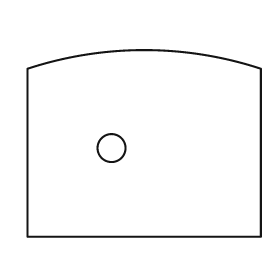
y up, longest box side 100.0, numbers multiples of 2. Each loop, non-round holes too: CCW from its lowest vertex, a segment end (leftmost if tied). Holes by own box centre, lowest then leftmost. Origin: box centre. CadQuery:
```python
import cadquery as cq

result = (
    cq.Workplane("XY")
    .moveTo(-50.0, -40.0)
    .lineTo(50.0, -40.0)
    .lineTo(50.0, 32.0)
    .threePointArc((0.0, 40.0), (-50.0, 32.0))
    .close()
    .moveTo(-14.0, -2.0)
    .circle(6.0)
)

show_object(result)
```